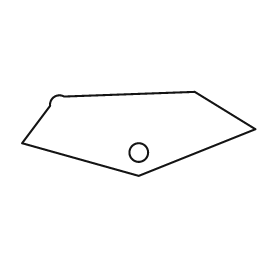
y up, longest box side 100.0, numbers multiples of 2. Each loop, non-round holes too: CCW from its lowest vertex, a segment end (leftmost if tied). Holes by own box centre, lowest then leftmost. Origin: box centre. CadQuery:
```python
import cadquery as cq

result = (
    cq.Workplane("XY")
    .moveTo(0.0, -18.0)
    .lineTo(50.0, 2.0)
    .lineTo(24.0, 18.0)
    .lineTo(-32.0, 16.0)
    .threePointArc((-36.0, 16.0), (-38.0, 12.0))
    .lineTo(-50.0, -4.0)
    .close()
    .moveTo(0.0, -8.0)
    .circle(4.0)
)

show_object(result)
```